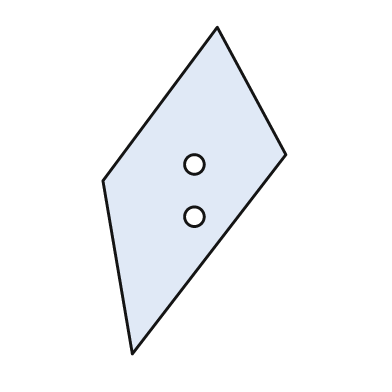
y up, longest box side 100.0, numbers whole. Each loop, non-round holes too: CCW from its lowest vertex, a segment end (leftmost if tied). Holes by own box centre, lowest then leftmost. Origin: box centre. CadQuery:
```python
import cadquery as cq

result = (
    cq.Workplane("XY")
    .moveTo(-19.0, -50.0)
    .lineTo(28.0, 11.0)
    .lineTo(7.0, 50.0)
    .lineTo(-28.0, 3.0)
    .close()
    .moveTo(0.0, -8.0)
    .circle(3.0)
    .moveTo(0.0, 8.0)
    .circle(3.0)
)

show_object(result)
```